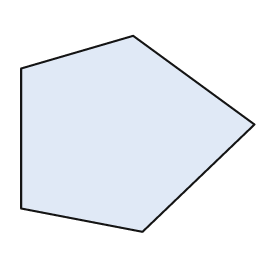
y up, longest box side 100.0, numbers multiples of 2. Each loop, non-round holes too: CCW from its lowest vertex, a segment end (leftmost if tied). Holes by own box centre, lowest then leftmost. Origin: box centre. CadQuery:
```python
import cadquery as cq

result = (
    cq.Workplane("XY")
    .moveTo(2.0, -42.0)
    .lineTo(50.0, 4.0)
    .lineTo(-2.0, 42.0)
    .lineTo(-50.0, 28.0)
    .lineTo(-50.0, -32.0)
    .close()
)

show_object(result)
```